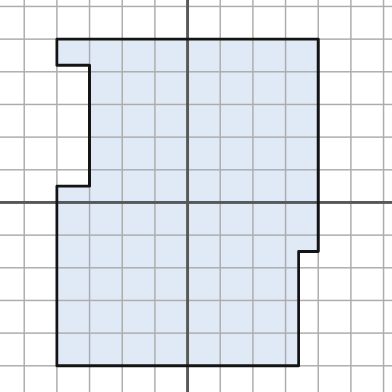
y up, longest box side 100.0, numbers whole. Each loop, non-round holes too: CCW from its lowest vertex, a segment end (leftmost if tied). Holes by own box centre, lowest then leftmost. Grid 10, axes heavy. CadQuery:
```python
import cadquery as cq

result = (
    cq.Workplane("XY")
    .moveTo(-40.0, -50.0)
    .lineTo(34.0, -50.0)
    .lineTo(34.0, -15.0)
    .lineTo(40.0, -15.0)
    .lineTo(40.0, 50.0)
    .lineTo(-40.0, 50.0)
    .lineTo(-40.0, 42.0)
    .lineTo(-30.0, 42.0)
    .lineTo(-30.0, 5.0)
    .lineTo(-40.0, 5.0)
    .close()
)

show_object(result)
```